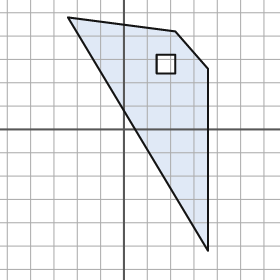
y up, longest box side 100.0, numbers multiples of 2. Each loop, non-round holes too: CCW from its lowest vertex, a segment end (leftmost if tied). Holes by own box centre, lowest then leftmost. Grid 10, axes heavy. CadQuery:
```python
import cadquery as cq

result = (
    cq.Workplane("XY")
    .moveTo(36.0, -52.0)
    .lineTo(36.0, 26.0)
    .lineTo(22.0, 42.0)
    .lineTo(-24.0, 48.0)
    .close()
    .moveTo(14.0, 24.0)
    .lineTo(22.0, 24.0)
    .lineTo(22.0, 32.0)
    .lineTo(14.0, 32.0)
    .close()
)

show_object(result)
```